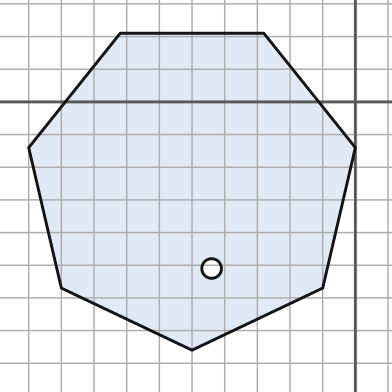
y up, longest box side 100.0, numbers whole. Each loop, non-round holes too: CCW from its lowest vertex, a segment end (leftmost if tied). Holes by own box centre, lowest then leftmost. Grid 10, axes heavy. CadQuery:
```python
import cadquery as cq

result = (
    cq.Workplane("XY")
    .moveTo(-50.0, -76.0)
    .lineTo(-10.0, -57.0)
    .lineTo(0.0, -14.0)
    .lineTo(-28.0, 21.0)
    .lineTo(-72.0, 21.0)
    .lineTo(-100.0, -14.0)
    .lineTo(-90.0, -57.0)
    .close()
    .moveTo(-44.0, -51.0)
    .circle(3.0)
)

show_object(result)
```